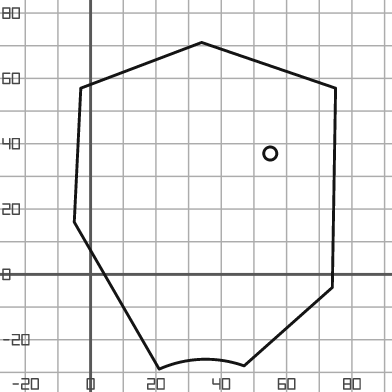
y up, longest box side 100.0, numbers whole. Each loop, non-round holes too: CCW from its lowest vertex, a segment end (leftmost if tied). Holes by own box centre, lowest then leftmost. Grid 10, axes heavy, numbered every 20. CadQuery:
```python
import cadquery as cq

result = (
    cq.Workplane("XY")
    .moveTo(21.0, -29.0)
    .threePointArc((34.0, -26.0), (47.0, -28.0))
    .lineTo(74.0, -4.0)
    .lineTo(75.0, 57.0)
    .lineTo(34.0, 71.0)
    .lineTo(-3.0, 57.0)
    .lineTo(-5.0, 16.0)
    .close()
    .moveTo(55.0, 37.0)
    .circle(2.0)
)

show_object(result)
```